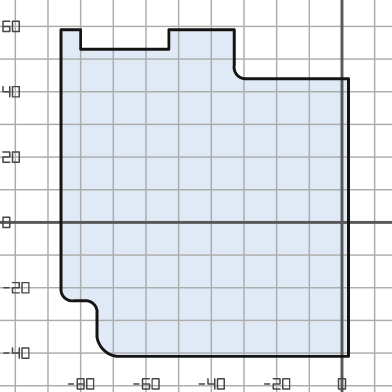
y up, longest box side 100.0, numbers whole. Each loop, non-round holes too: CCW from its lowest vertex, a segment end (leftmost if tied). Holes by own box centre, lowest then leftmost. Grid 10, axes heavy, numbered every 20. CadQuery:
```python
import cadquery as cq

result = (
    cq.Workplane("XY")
    .moveTo(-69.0, -41.0)
    .lineTo(2.0, -41.0)
    .lineTo(2.0, 44.0)
    .lineTo(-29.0, 44.0)
    .threePointArc((-32.0, 45.0), (-33.0, 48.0))
    .lineTo(-33.0, 59.0)
    .lineTo(-53.0, 59.0)
    .lineTo(-53.0, 53.0)
    .lineTo(-80.0, 53.0)
    .lineTo(-80.0, 59.0)
    .lineTo(-86.0, 59.0)
    .lineTo(-86.0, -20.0)
    .threePointArc((-85.0, -23.0), (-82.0, -24.0))
    .lineTo(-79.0, -24.0)
    .threePointArc((-76.0, -25.0), (-75.0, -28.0))
    .lineTo(-75.0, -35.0)
    .threePointArc((-73.0, -39.0), (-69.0, -41.0))
    .close()
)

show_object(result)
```